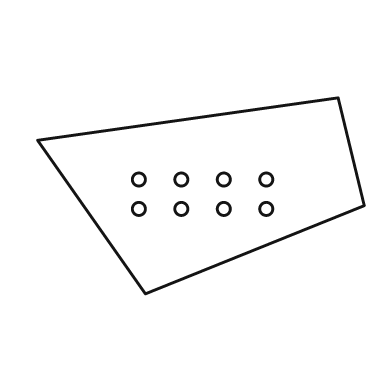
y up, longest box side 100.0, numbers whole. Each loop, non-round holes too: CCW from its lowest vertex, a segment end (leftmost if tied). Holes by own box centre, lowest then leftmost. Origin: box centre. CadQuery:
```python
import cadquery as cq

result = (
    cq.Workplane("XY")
    .moveTo(-17.0, -30.0)
    .lineTo(50.0, -3.0)
    .lineTo(42.0, 30.0)
    .lineTo(-50.0, 17.0)
    .close()
    .moveTo(-19.0, -4.0)
    .circle(2.0)
    .moveTo(-6.0, -4.0)
    .circle(2.0)
    .moveTo(7.0, -4.0)
    .circle(2.0)
    .moveTo(20.0, -4.0)
    .circle(2.0)
    .moveTo(-19.0, 5.0)
    .circle(2.0)
    .moveTo(-6.0, 5.0)
    .circle(2.0)
    .moveTo(7.0, 5.0)
    .circle(2.0)
    .moveTo(20.0, 5.0)
    .circle(2.0)
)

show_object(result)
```